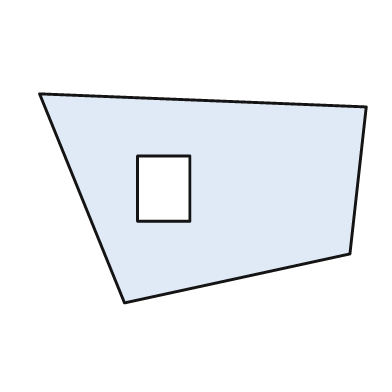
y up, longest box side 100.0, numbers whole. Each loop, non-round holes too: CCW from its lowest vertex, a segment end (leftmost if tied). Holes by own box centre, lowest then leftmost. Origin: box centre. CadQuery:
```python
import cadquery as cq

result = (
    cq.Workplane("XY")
    .moveTo(-24.0, -32.0)
    .lineTo(45.0, -17.0)
    .lineTo(50.0, 28.0)
    .lineTo(-50.0, 32.0)
    .close()
    .moveTo(-20.0, -7.0)
    .lineTo(-4.0, -7.0)
    .lineTo(-4.0, 13.0)
    .lineTo(-20.0, 13.0)
    .close()
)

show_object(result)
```